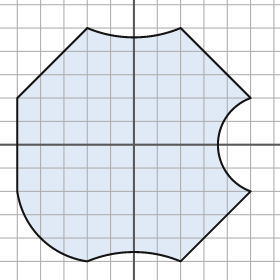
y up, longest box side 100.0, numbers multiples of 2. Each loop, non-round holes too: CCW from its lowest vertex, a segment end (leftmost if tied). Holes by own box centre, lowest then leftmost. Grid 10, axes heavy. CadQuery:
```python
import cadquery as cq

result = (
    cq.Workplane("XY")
    .moveTo(-20.0, -50.0)
    .threePointArc((0.0, -46.0), (20.0, -50.0))
    .lineTo(50.0, -20.0)
    .threePointArc((36.0, 0.0), (50.0, 20.0))
    .lineTo(20.0, 50.0)
    .threePointArc((0.0, 46.0), (-20.0, 50.0))
    .lineTo(-50.0, 20.0)
    .lineTo(-50.0, -20.0)
    .threePointArc((-40.0, -40.0), (-20.0, -50.0))
    .close()
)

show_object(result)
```